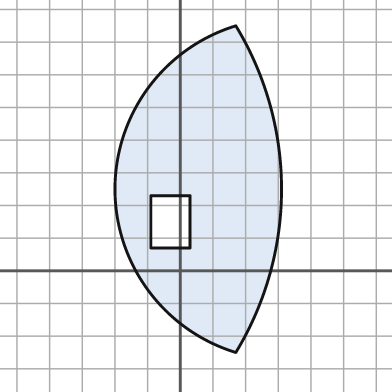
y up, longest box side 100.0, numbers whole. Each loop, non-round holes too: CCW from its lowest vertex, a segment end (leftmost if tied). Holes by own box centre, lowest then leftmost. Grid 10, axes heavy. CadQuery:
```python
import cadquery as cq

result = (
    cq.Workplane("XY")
    .moveTo(17.0, -25.0)
    .threePointArc((31.0, 25.0), (17.0, 75.0))
    .threePointArc((-20.0, 25.0), (17.0, -25.0))
    .close()
    .moveTo(-9.0, 7.0)
    .lineTo(3.0, 7.0)
    .lineTo(3.0, 23.0)
    .lineTo(-9.0, 23.0)
    .close()
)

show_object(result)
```